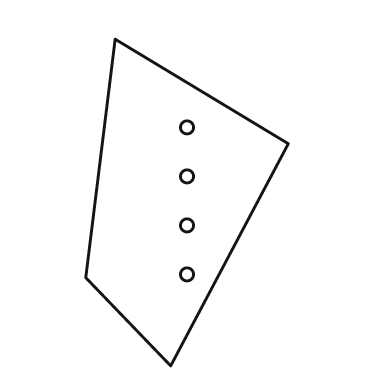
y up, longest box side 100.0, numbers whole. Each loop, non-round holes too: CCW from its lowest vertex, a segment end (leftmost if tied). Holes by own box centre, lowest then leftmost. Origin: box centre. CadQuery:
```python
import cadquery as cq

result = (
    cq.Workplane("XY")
    .moveTo(-5.0, -50.0)
    .lineTo(31.0, 18.0)
    .lineTo(-22.0, 50.0)
    .lineTo(-31.0, -23.0)
    .close()
    .moveTo(0.0, -22.0)
    .circle(2.0)
    .moveTo(0.0, -7.0)
    .circle(2.0)
    .moveTo(0.0, 8.0)
    .circle(2.0)
    .moveTo(0.0, 23.0)
    .circle(2.0)
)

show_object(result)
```